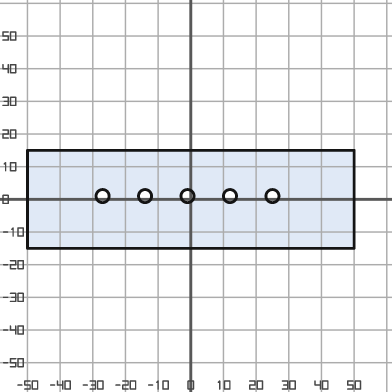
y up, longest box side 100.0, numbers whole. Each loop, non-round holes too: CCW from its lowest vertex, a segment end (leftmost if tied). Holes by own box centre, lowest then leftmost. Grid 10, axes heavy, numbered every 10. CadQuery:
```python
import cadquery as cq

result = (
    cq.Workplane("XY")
    .moveTo(-50.0, -15.0)
    .lineTo(50.0, -15.0)
    .lineTo(50.0, 15.0)
    .lineTo(-50.0, 15.0)
    .close()
    .moveTo(-27.0, 1.0)
    .circle(2.0)
    .moveTo(-14.0, 1.0)
    .circle(2.0)
    .moveTo(-1.0, 1.0)
    .circle(2.0)
    .moveTo(12.0, 1.0)
    .circle(2.0)
    .moveTo(25.0, 1.0)
    .circle(2.0)
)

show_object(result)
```